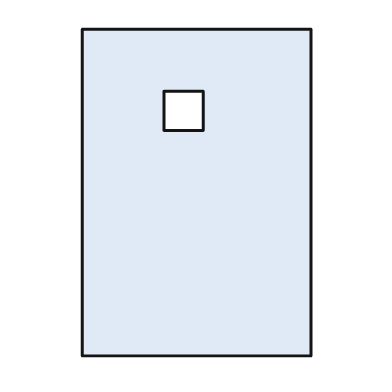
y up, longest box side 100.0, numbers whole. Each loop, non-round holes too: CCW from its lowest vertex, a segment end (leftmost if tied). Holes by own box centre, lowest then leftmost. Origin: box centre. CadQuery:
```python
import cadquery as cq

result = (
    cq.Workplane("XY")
    .moveTo(-35.0, -50.0)
    .lineTo(35.0, -50.0)
    .lineTo(35.0, 50.0)
    .lineTo(-35.0, 50.0)
    .close()
    .moveTo(-10.0, 19.0)
    .lineTo(2.0, 19.0)
    .lineTo(2.0, 31.0)
    .lineTo(-10.0, 31.0)
    .close()
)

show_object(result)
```